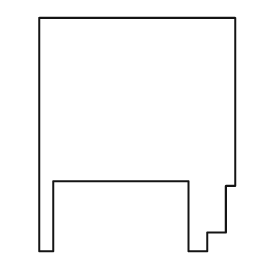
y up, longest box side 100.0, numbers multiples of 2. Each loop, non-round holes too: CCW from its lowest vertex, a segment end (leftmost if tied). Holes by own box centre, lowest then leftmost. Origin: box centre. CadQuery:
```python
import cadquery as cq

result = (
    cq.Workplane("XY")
    .moveTo(-42.0, -50.0)
    .lineTo(-36.0, -50.0)
    .lineTo(-36.0, -20.0)
    .lineTo(22.0, -20.0)
    .lineTo(22.0, -50.0)
    .lineTo(30.0, -50.0)
    .lineTo(30.0, -42.0)
    .lineTo(38.0, -42.0)
    .lineTo(38.0, -22.0)
    .lineTo(42.0, -22.0)
    .lineTo(42.0, 50.0)
    .lineTo(-42.0, 50.0)
    .close()
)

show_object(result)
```